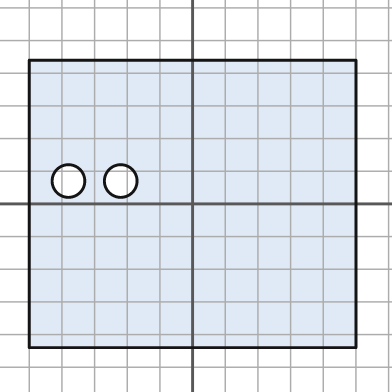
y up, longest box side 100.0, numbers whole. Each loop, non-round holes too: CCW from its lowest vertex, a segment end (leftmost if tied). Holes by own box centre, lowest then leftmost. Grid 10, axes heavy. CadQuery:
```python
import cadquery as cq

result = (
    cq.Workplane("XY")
    .moveTo(-50.0, -44.0)
    .lineTo(50.0, -44.0)
    .lineTo(50.0, 44.0)
    .lineTo(-50.0, 44.0)
    .close()
    .moveTo(-38.0, 7.0)
    .circle(5.0)
    .moveTo(-22.0, 7.0)
    .circle(5.0)
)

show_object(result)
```